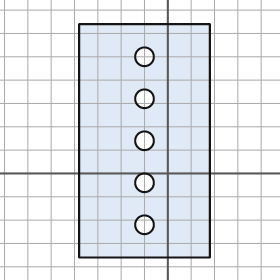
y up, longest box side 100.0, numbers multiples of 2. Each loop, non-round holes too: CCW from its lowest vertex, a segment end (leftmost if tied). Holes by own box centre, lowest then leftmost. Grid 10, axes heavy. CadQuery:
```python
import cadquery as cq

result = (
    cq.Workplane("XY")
    .moveTo(-38.0, -36.0)
    .lineTo(18.0, -36.0)
    .lineTo(18.0, 64.0)
    .lineTo(-38.0, 64.0)
    .close()
    .moveTo(-10.0, -22.0)
    .circle(4.0)
    .moveTo(-10.0, -4.0)
    .circle(4.0)
    .moveTo(-10.0, 14.0)
    .circle(4.0)
    .moveTo(-10.0, 32.0)
    .circle(4.0)
    .moveTo(-10.0, 50.0)
    .circle(4.0)
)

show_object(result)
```